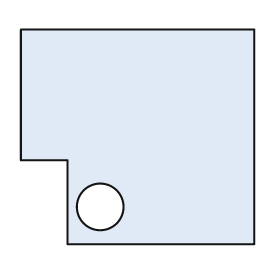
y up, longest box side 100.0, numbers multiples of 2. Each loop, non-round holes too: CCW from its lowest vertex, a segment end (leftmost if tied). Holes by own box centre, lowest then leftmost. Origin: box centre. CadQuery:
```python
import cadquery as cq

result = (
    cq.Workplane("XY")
    .moveTo(-30.0, -46.0)
    .lineTo(50.0, -46.0)
    .lineTo(50.0, 46.0)
    .lineTo(-50.0, 46.0)
    .lineTo(-50.0, -10.0)
    .lineTo(-30.0, -10.0)
    .close()
    .moveTo(-16.0, -30.0)
    .circle(10.0)
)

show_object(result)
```